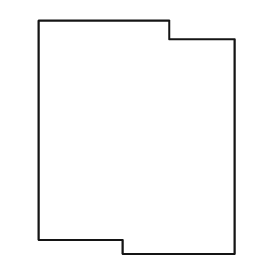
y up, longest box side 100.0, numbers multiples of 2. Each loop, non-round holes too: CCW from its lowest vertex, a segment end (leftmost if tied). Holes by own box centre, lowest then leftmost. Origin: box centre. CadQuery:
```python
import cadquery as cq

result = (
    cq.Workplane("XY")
    .moveTo(-6.0, -50.0)
    .lineTo(42.0, -50.0)
    .lineTo(42.0, 42.0)
    .lineTo(14.0, 42.0)
    .lineTo(14.0, 50.0)
    .lineTo(-42.0, 50.0)
    .lineTo(-42.0, -44.0)
    .lineTo(-6.0, -44.0)
    .close()
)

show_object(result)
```